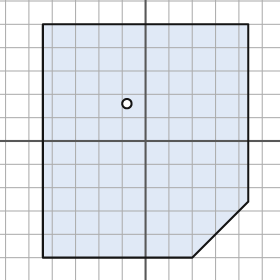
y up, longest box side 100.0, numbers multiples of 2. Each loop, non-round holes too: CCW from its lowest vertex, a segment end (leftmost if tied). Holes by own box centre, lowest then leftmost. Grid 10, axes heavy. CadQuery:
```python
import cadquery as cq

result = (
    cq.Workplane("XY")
    .moveTo(-44.0, -50.0)
    .lineTo(20.0, -50.0)
    .lineTo(44.0, -26.0)
    .lineTo(44.0, 50.0)
    .lineTo(-44.0, 50.0)
    .close()
    .moveTo(-8.0, 16.0)
    .circle(2.0)
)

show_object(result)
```